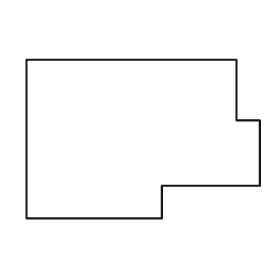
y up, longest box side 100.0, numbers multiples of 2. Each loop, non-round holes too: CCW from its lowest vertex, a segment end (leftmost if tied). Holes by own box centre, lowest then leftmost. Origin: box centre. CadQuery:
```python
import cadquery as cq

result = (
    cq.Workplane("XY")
    .moveTo(-50.0, -34.0)
    .lineTo(8.0, -34.0)
    .lineTo(8.0, -20.0)
    .lineTo(50.0, -20.0)
    .lineTo(50.0, 8.0)
    .lineTo(40.0, 8.0)
    .lineTo(40.0, 34.0)
    .lineTo(-50.0, 34.0)
    .close()
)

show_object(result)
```